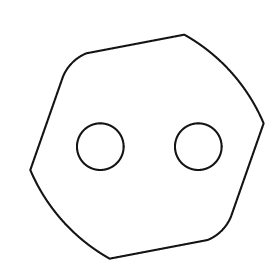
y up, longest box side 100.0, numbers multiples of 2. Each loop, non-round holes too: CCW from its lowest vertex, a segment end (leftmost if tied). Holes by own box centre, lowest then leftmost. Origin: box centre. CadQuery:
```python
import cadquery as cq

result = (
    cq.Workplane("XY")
    .moveTo(-16.0, -48.0)
    .lineTo(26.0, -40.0)
    .threePointArc((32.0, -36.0), (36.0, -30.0))
    .lineTo(50.0, 10.0)
    .threePointArc((36.0, 32.0), (16.0, 48.0))
    .lineTo(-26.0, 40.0)
    .threePointArc((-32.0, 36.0), (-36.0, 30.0))
    .lineTo(-50.0, -10.0)
    .threePointArc((-36.0, -32.0), (-16.0, -48.0))
    .close()
    .moveTo(-20.0, 0.0)
    .circle(10.0)
    .moveTo(22.0, 0.0)
    .circle(10.0)
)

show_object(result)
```